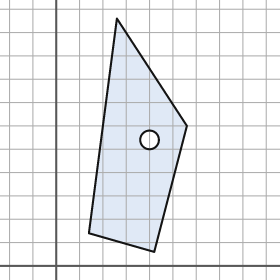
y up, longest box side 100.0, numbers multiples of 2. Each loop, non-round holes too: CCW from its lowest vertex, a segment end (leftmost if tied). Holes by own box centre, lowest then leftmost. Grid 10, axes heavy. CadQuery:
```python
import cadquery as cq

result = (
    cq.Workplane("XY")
    .moveTo(42.0, 6.0)
    .lineTo(56.0, 60.0)
    .lineTo(26.0, 106.0)
    .lineTo(14.0, 14.0)
    .close()
    .moveTo(40.0, 54.0)
    .circle(4.0)
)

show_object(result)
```